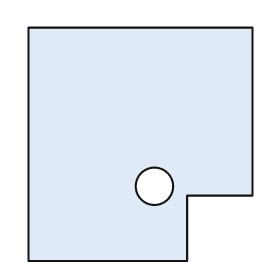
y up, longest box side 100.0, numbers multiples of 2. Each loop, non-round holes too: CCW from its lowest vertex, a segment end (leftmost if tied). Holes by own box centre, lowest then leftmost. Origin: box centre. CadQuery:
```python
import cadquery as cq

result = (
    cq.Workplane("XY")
    .moveTo(-48.0, -50.0)
    .lineTo(20.0, -50.0)
    .lineTo(20.0, -22.0)
    .lineTo(48.0, -22.0)
    .lineTo(48.0, 50.0)
    .lineTo(-48.0, 50.0)
    .close()
    .moveTo(6.0, -18.0)
    .circle(8.0)
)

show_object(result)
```